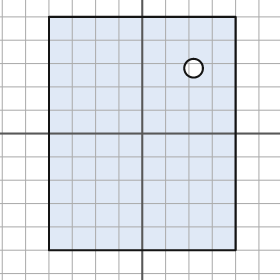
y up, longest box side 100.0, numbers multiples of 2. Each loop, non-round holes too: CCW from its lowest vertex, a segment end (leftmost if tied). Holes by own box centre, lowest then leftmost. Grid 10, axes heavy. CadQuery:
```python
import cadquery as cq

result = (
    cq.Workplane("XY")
    .moveTo(-40.0, -50.0)
    .lineTo(40.0, -50.0)
    .lineTo(40.0, 50.0)
    .lineTo(-40.0, 50.0)
    .close()
    .moveTo(22.0, 28.0)
    .circle(4.0)
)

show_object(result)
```